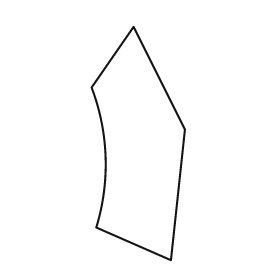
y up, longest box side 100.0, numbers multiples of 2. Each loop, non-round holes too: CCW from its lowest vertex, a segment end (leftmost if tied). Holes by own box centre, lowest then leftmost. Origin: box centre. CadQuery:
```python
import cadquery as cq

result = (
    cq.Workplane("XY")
    .moveTo(14.0, -50.0)
    .lineTo(20.0, 6.0)
    .lineTo(-2.0, 50.0)
    .lineTo(-20.0, 24.0)
    .threePointArc((-14.0, -6.0), (-18.0, -36.0))
    .close()
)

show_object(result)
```